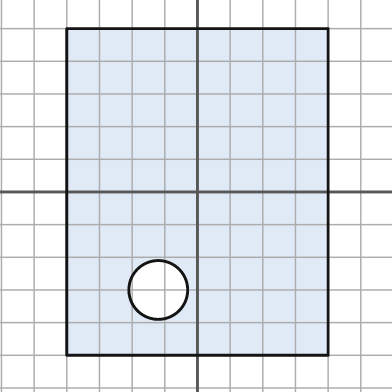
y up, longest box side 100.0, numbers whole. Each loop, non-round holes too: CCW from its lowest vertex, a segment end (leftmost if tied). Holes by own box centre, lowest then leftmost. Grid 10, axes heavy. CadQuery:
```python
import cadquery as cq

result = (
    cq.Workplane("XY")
    .moveTo(-40.0, -50.0)
    .lineTo(40.0, -50.0)
    .lineTo(40.0, 50.0)
    .lineTo(-40.0, 50.0)
    .close()
    .moveTo(-12.0, -30.0)
    .circle(9.0)
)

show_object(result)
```